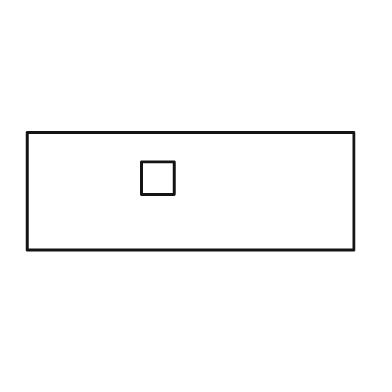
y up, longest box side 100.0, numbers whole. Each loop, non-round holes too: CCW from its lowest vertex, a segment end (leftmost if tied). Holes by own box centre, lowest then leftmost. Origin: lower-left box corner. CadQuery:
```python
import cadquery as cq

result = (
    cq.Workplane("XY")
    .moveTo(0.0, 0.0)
    .lineTo(100.0, 0.0)
    .lineTo(100.0, 36.0)
    .lineTo(0.0, 36.0)
    .close()
    .moveTo(35.0, 17.0)
    .lineTo(45.0, 17.0)
    .lineTo(45.0, 27.0)
    .lineTo(35.0, 27.0)
    .close()
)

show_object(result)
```